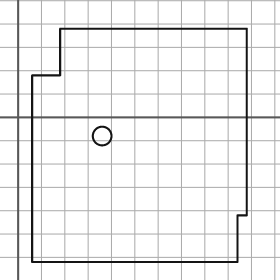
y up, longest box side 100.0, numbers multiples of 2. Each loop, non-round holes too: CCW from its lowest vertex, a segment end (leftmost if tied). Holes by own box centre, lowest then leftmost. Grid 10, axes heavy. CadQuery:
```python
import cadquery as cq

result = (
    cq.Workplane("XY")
    .moveTo(6.0, -62.0)
    .lineTo(94.0, -62.0)
    .lineTo(94.0, -42.0)
    .lineTo(98.0, -42.0)
    .lineTo(98.0, 38.0)
    .lineTo(18.0, 38.0)
    .lineTo(18.0, 18.0)
    .lineTo(6.0, 18.0)
    .close()
    .moveTo(36.0, -8.0)
    .circle(4.0)
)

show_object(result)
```